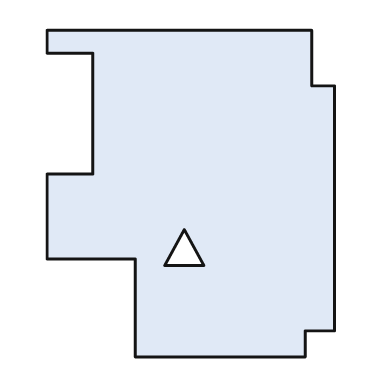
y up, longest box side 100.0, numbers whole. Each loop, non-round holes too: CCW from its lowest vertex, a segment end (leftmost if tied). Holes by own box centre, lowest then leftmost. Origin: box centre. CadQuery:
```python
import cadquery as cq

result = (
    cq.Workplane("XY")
    .moveTo(-17.0, -50.0)
    .lineTo(35.0, -50.0)
    .lineTo(35.0, -42.0)
    .lineTo(44.0, -42.0)
    .lineTo(44.0, 33.0)
    .lineTo(37.0, 33.0)
    .lineTo(37.0, 50.0)
    .lineTo(-44.0, 50.0)
    .lineTo(-44.0, 43.0)
    .lineTo(-30.0, 43.0)
    .lineTo(-30.0, 6.0)
    .lineTo(-44.0, 6.0)
    .lineTo(-44.0, -20.0)
    .lineTo(-17.0, -20.0)
    .close()
    .moveTo(-8.0, -22.0)
    .lineTo(4.0, -22.0)
    .lineTo(-2.0, -11.0)
    .close()
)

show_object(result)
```